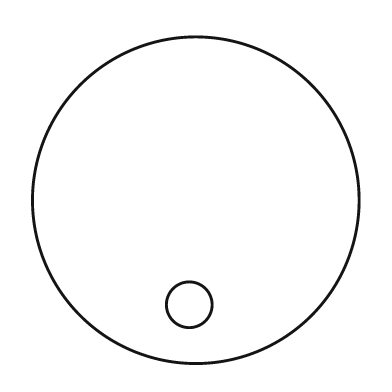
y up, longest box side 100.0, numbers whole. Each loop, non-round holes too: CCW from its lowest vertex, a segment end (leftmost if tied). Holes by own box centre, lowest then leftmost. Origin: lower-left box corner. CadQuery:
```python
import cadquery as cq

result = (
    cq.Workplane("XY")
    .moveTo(50.0, 50.0)
    .circle(50.0)
    .moveTo(48.0, 18.0)
    .circle(7.0)
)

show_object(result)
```